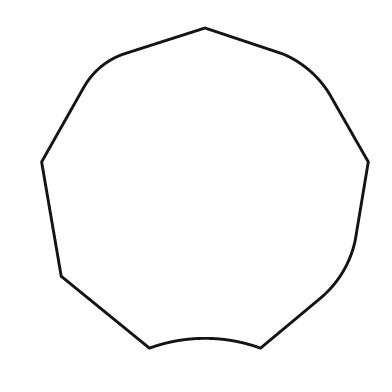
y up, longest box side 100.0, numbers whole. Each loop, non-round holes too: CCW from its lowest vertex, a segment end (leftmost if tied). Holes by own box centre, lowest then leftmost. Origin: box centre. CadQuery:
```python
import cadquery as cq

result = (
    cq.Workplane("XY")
    .moveTo(-17.0, -49.0)
    .threePointArc((0.0, -46.0), (17.0, -49.0))
    .lineTo(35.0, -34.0)
    .threePointArc((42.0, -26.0), (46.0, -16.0))
    .lineTo(50.0, 8.0)
    .lineTo(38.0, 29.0)
    .threePointArc((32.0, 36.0), (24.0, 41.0))
    .lineTo(0.0, 49.0)
    .lineTo(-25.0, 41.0)
    .threePointArc((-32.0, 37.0), (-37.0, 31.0))
    .lineTo(-50.0, 8.0)
    .lineTo(-44.0, -27.0)
    .close()
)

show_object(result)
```